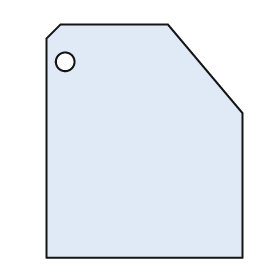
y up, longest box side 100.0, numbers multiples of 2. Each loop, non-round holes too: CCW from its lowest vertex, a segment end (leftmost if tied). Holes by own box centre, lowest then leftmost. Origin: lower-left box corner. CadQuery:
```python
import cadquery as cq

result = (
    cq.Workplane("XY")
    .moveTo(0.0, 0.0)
    .lineTo(84.0, 0.0)
    .lineTo(84.0, 62.0)
    .lineTo(52.0, 100.0)
    .lineTo(6.0, 100.0)
    .lineTo(0.0, 94.0)
    .close()
    .moveTo(8.0, 84.0)
    .circle(4.0)
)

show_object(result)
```